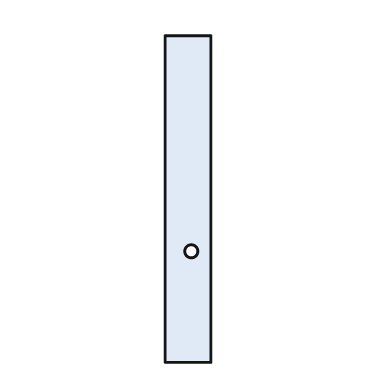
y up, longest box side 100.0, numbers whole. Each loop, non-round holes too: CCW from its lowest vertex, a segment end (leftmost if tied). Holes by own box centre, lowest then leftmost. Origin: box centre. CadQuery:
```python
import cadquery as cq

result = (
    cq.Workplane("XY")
    .moveTo(-7.0, -50.0)
    .lineTo(7.0, -50.0)
    .lineTo(7.0, 50.0)
    .lineTo(-7.0, 50.0)
    .close()
    .moveTo(1.0, -16.0)
    .circle(2.0)
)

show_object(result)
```